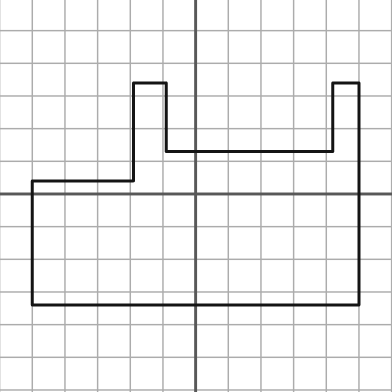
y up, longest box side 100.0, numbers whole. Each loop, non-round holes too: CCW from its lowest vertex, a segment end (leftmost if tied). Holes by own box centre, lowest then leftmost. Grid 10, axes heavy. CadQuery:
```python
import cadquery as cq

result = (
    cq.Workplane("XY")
    .moveTo(-50.0, -34.0)
    .lineTo(50.0, -34.0)
    .lineTo(50.0, 34.0)
    .lineTo(42.0, 34.0)
    .lineTo(42.0, 13.0)
    .lineTo(-9.0, 13.0)
    .lineTo(-9.0, 34.0)
    .lineTo(-19.0, 34.0)
    .lineTo(-19.0, 4.0)
    .lineTo(-50.0, 4.0)
    .close()
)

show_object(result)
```